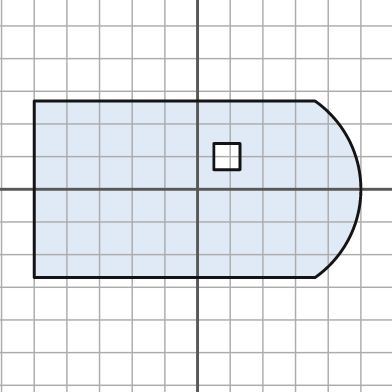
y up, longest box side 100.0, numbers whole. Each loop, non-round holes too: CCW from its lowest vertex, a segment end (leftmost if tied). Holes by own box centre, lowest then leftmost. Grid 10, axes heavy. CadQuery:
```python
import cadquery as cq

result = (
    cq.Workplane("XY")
    .moveTo(-50.0, -27.0)
    .lineTo(36.0, -27.0)
    .threePointArc((50.0, 0.0), (36.0, 27.0))
    .lineTo(-50.0, 27.0)
    .close()
    .moveTo(5.0, 6.0)
    .lineTo(13.0, 6.0)
    .lineTo(13.0, 14.0)
    .lineTo(5.0, 14.0)
    .close()
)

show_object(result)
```